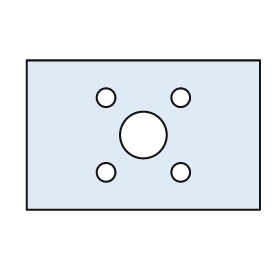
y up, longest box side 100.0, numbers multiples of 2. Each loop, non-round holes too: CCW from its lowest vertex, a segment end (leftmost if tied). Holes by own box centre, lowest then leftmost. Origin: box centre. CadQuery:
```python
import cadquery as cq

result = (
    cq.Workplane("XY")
    .moveTo(-50.0, -32.0)
    .lineTo(50.0, -32.0)
    .lineTo(50.0, 32.0)
    .lineTo(-50.0, 32.0)
    .close()
    .moveTo(-16.0, -16.0)
    .circle(4.0)
    .moveTo(16.0, -16.0)
    .circle(4.0)
    .moveTo(0.0, 0.0)
    .circle(10.0)
    .moveTo(-16.0, 16.0)
    .circle(4.0)
    .moveTo(16.0, 16.0)
    .circle(4.0)
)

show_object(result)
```